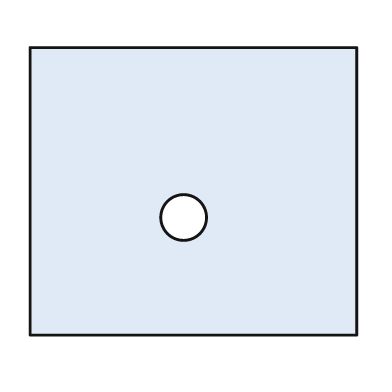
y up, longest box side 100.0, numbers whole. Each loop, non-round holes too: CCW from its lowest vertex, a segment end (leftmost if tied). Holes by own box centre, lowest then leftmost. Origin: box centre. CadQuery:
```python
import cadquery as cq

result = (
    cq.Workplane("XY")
    .moveTo(-50.0, -44.0)
    .lineTo(50.0, -44.0)
    .lineTo(50.0, 44.0)
    .lineTo(-50.0, 44.0)
    .close()
    .moveTo(-3.0, -8.0)
    .circle(7.0)
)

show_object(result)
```